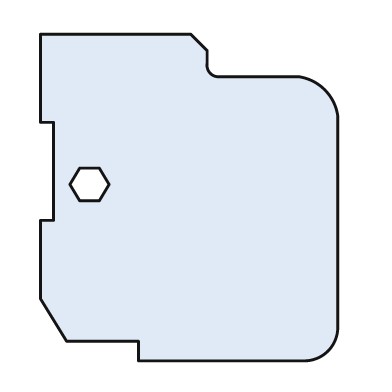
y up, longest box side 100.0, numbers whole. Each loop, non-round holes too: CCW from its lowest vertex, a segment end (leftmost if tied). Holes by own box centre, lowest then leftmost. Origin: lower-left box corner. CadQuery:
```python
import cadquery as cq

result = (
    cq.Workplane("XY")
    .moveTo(30.0, 0.0)
    .lineTo(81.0, 0.0)
    .threePointArc((88.0, 3.0), (91.0, 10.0))
    .lineTo(91.0, 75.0)
    .threePointArc((87.0, 83.0), (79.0, 87.0))
    .lineTo(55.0, 87.0)
    .threePointArc((52.0, 88.0), (51.0, 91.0))
    .lineTo(51.0, 95.0)
    .lineTo(46.0, 100.0)
    .lineTo(0.0, 100.0)
    .lineTo(0.0, 73.0)
    .lineTo(4.0, 73.0)
    .lineTo(4.0, 43.0)
    .lineTo(0.0, 43.0)
    .lineTo(0.0, 19.0)
    .lineTo(8.0, 6.0)
    .lineTo(30.0, 6.0)
    .close()
    .moveTo(12.0, 49.0)
    .lineTo(18.0, 49.0)
    .lineTo(21.0, 54.0)
    .lineTo(18.0, 59.0)
    .lineTo(12.0, 59.0)
    .lineTo(9.0, 54.0)
    .close()
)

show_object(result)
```